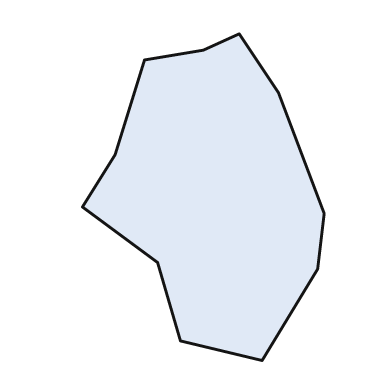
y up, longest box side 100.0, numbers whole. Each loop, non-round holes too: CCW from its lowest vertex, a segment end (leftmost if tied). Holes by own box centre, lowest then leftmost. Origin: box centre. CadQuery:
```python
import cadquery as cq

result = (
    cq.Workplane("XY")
    .moveTo(18.0, -50.0)
    .lineTo(35.0, -22.0)
    .lineTo(37.0, -5.0)
    .lineTo(23.0, 32.0)
    .lineTo(11.0, 50.0)
    .lineTo(0.0, 45.0)
    .lineTo(-18.0, 42.0)
    .lineTo(-27.0, 13.0)
    .lineTo(-37.0, -3.0)
    .lineTo(-14.0, -20.0)
    .lineTo(-7.0, -44.0)
    .close()
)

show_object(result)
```